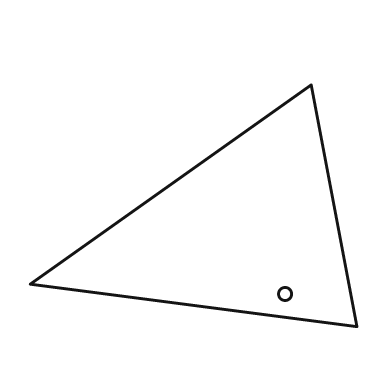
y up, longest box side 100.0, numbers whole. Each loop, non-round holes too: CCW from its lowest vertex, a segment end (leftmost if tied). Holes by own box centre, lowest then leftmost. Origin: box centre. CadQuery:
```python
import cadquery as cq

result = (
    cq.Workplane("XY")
    .moveTo(50.0, -37.0)
    .lineTo(36.0, 37.0)
    .lineTo(-50.0, -24.0)
    .close()
    .moveTo(28.0, -27.0)
    .circle(2.0)
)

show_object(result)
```